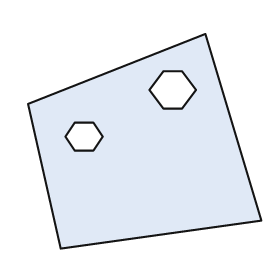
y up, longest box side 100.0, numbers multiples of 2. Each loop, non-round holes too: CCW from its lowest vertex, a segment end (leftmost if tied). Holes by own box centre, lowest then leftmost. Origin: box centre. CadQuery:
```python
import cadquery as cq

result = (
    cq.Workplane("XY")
    .moveTo(-36.0, -46.0)
    .lineTo(50.0, -34.0)
    .lineTo(26.0, 46.0)
    .lineTo(-50.0, 16.0)
    .close()
    .moveTo(-30.0, -4.0)
    .lineTo(-22.0, -4.0)
    .lineTo(-18.0, 2.0)
    .lineTo(-22.0, 8.0)
    .lineTo(-30.0, 8.0)
    .lineTo(-34.0, 2.0)
    .close()
    .moveTo(8.0, 14.0)
    .lineTo(16.0, 14.0)
    .lineTo(22.0, 22.0)
    .lineTo(16.0, 30.0)
    .lineTo(8.0, 30.0)
    .lineTo(2.0, 22.0)
    .close()
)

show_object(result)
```